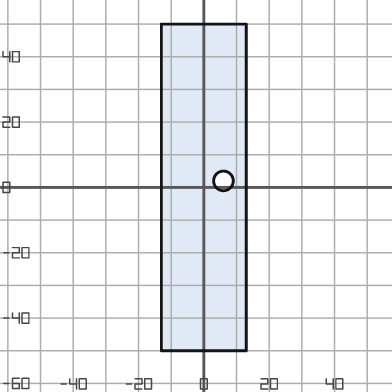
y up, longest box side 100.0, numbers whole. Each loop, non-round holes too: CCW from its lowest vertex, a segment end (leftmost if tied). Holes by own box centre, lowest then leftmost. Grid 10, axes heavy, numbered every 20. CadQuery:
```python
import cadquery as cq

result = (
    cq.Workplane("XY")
    .moveTo(-13.0, -50.0)
    .lineTo(13.0, -50.0)
    .lineTo(13.0, 50.0)
    .lineTo(-13.0, 50.0)
    .close()
    .moveTo(6.0, 2.0)
    .circle(3.0)
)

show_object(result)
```